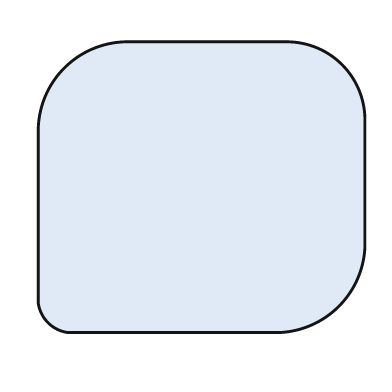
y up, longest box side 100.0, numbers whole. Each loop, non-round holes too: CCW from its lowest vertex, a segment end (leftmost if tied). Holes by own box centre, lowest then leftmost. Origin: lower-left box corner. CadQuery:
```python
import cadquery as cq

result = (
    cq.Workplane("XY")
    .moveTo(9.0, 0.0)
    .lineTo(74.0, 0.0)
    .threePointArc((92.0, 8.0), (100.0, 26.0))
    .lineTo(100.0, 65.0)
    .threePointArc((93.0, 82.0), (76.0, 89.0))
    .lineTo(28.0, 89.0)
    .threePointArc((8.0, 81.0), (0.0, 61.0))
    .lineTo(0.0, 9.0)
    .threePointArc((3.0, 3.0), (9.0, 0.0))
    .close()
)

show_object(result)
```